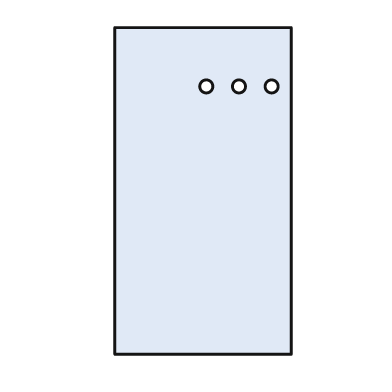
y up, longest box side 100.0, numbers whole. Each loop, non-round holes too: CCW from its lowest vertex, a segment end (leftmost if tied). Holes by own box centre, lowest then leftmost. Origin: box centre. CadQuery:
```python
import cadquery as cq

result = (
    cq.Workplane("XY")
    .moveTo(-27.0, -50.0)
    .lineTo(27.0, -50.0)
    .lineTo(27.0, 50.0)
    .lineTo(-27.0, 50.0)
    .close()
    .moveTo(1.0, 32.0)
    .circle(2.0)
    .moveTo(11.0, 32.0)
    .circle(2.0)
    .moveTo(21.0, 32.0)
    .circle(2.0)
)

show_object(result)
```